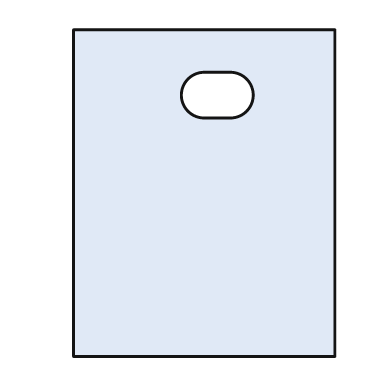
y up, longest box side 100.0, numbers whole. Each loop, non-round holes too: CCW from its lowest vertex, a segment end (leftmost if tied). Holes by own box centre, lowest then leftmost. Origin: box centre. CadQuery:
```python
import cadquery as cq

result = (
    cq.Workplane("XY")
    .moveTo(-40.0, -50.0)
    .lineTo(40.0, -50.0)
    .lineTo(40.0, 50.0)
    .lineTo(-40.0, 50.0)
    .close()
    .moveTo(0.0, 23.0)
    .lineTo(8.0, 23.0)
    .threePointArc((15.0, 30.0), (8.0, 37.0))
    .lineTo(0.0, 37.0)
    .threePointArc((-7.0, 30.0), (0.0, 23.0))
    .close()
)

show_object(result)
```